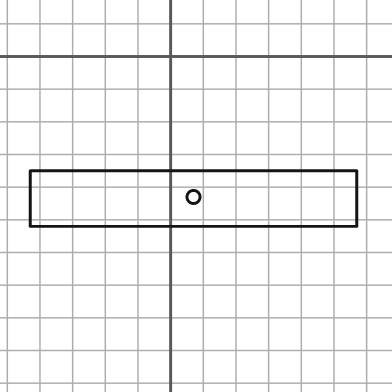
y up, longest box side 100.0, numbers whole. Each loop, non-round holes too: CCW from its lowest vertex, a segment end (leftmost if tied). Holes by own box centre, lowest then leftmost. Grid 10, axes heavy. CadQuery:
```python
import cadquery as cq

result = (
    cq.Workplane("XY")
    .moveTo(-43.0, -52.0)
    .lineTo(57.0, -52.0)
    .lineTo(57.0, -35.0)
    .lineTo(-43.0, -35.0)
    .close()
    .moveTo(7.0, -43.0)
    .circle(2.0)
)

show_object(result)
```